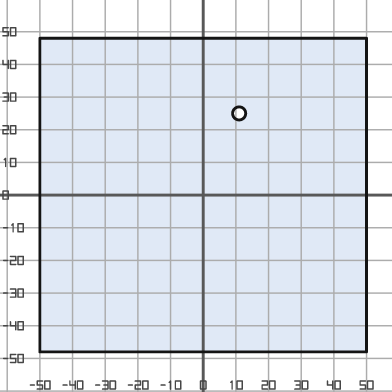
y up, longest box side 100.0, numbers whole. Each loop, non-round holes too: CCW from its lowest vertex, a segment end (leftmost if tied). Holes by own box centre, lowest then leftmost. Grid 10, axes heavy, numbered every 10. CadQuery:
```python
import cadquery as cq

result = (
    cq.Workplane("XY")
    .moveTo(-50.0, -48.0)
    .lineTo(50.0, -48.0)
    .lineTo(50.0, 48.0)
    .lineTo(-50.0, 48.0)
    .close()
    .moveTo(11.0, 25.0)
    .circle(2.0)
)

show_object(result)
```